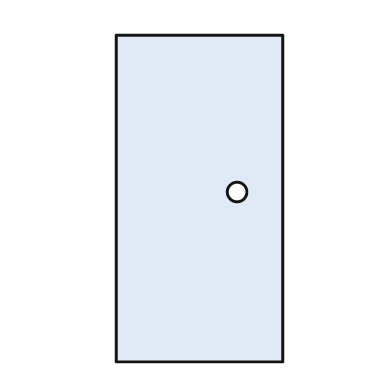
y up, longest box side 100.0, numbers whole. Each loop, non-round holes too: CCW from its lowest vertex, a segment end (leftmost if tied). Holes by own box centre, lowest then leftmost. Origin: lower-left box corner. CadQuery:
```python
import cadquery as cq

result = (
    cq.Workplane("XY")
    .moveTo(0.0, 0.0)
    .lineTo(51.0, 0.0)
    .lineTo(51.0, 100.0)
    .lineTo(0.0, 100.0)
    .close()
    .moveTo(37.0, 52.0)
    .circle(3.0)
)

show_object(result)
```